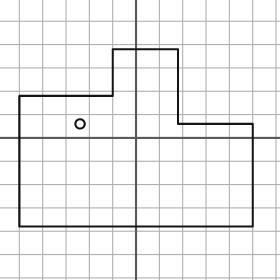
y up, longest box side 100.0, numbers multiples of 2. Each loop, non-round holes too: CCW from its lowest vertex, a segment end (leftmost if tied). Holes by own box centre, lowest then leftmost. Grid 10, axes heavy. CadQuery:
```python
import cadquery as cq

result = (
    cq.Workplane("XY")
    .moveTo(-50.0, -38.0)
    .lineTo(50.0, -38.0)
    .lineTo(50.0, 6.0)
    .lineTo(18.0, 6.0)
    .lineTo(18.0, 38.0)
    .lineTo(-10.0, 38.0)
    .lineTo(-10.0, 18.0)
    .lineTo(-50.0, 18.0)
    .close()
    .moveTo(-24.0, 6.0)
    .circle(2.0)
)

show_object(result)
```